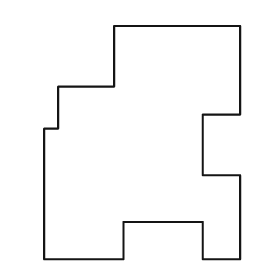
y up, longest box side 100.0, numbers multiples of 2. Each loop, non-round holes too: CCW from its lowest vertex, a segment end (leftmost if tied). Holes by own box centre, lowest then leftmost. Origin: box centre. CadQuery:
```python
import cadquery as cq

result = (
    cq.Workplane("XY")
    .moveTo(-42.0, -50.0)
    .lineTo(-8.0, -50.0)
    .lineTo(-8.0, -34.0)
    .lineTo(26.0, -34.0)
    .lineTo(26.0, -50.0)
    .lineTo(42.0, -50.0)
    .lineTo(42.0, -14.0)
    .lineTo(26.0, -14.0)
    .lineTo(26.0, 12.0)
    .lineTo(42.0, 12.0)
    .lineTo(42.0, 50.0)
    .lineTo(-12.0, 50.0)
    .lineTo(-12.0, 24.0)
    .lineTo(-36.0, 24.0)
    .lineTo(-36.0, 6.0)
    .lineTo(-42.0, 6.0)
    .close()
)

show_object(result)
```